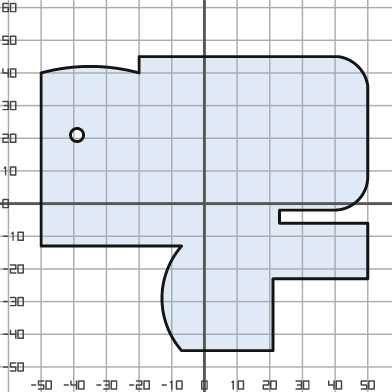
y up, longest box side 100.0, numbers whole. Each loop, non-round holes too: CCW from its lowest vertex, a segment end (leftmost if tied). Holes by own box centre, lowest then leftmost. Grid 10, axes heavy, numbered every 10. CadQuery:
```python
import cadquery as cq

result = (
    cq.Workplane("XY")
    .moveTo(-7.0, -45.0)
    .lineTo(21.0, -45.0)
    .lineTo(21.0, -23.0)
    .lineTo(50.0, -23.0)
    .lineTo(50.0, -6.0)
    .lineTo(23.0, -6.0)
    .lineTo(23.0, -2.0)
    .lineTo(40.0, -2.0)
    .threePointArc((47.0, 1.0), (50.0, 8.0))
    .lineTo(50.0, 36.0)
    .threePointArc((47.0, 42.0), (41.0, 45.0))
    .lineTo(-20.0, 45.0)
    .lineTo(-20.0, 40.0)
    .threePointArc((-35.0, 42.0), (-50.0, 40.0))
    .lineTo(-50.0, -13.0)
    .lineTo(-7.0, -13.0)
    .threePointArc((-13.0, -29.0), (-7.0, -45.0))
    .close()
    .moveTo(-39.0, 21.0)
    .circle(2.0)
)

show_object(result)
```